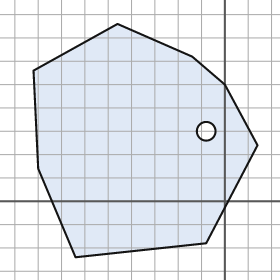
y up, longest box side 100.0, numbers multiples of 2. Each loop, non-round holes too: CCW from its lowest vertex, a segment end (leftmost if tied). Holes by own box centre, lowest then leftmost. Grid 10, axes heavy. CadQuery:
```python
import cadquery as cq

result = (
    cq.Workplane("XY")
    .moveTo(-64.0, -24.0)
    .lineTo(-8.0, -18.0)
    .lineTo(14.0, 24.0)
    .lineTo(0.0, 50.0)
    .lineTo(-14.0, 62.0)
    .lineTo(-46.0, 76.0)
    .lineTo(-82.0, 56.0)
    .lineTo(-80.0, 14.0)
    .close()
    .moveTo(-8.0, 30.0)
    .circle(4.0)
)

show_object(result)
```